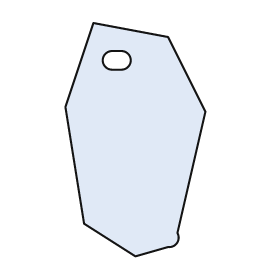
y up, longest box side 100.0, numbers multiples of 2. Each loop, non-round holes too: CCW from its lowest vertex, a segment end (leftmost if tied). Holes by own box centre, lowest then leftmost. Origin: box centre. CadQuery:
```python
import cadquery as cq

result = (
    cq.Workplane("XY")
    .moveTo(0.0, -50.0)
    .lineTo(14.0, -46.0)
    .threePointArc((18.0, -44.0), (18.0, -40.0))
    .lineTo(30.0, 12.0)
    .lineTo(14.0, 44.0)
    .lineTo(-18.0, 50.0)
    .lineTo(-30.0, 14.0)
    .lineTo(-22.0, -36.0)
    .close()
    .moveTo(-10.0, 30.0)
    .lineTo(-6.0, 30.0)
    .threePointArc((-2.0, 34.0), (-6.0, 38.0))
    .lineTo(-10.0, 38.0)
    .threePointArc((-14.0, 34.0), (-10.0, 30.0))
    .close()
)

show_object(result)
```